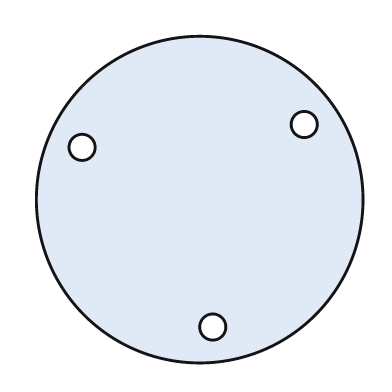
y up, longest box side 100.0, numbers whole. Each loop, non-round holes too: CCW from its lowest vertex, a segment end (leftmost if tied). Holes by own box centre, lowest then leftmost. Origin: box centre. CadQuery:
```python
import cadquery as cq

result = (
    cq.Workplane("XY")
    .moveTo(0.0, 0.0)
    .circle(50.0)
    .moveTo(4.0, -39.0)
    .circle(4.0)
    .moveTo(-36.0, 16.0)
    .circle(4.0)
    .moveTo(32.0, 23.0)
    .circle(4.0)
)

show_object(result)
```